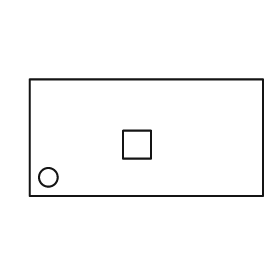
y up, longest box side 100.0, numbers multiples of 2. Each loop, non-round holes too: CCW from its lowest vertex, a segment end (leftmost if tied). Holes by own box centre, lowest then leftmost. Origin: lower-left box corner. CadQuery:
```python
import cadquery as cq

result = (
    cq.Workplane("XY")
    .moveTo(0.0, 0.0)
    .lineTo(100.0, 0.0)
    .lineTo(100.0, 50.0)
    .lineTo(0.0, 50.0)
    .close()
    .moveTo(8.0, 8.0)
    .circle(4.0)
    .moveTo(40.0, 16.0)
    .lineTo(52.0, 16.0)
    .lineTo(52.0, 28.0)
    .lineTo(40.0, 28.0)
    .close()
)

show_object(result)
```